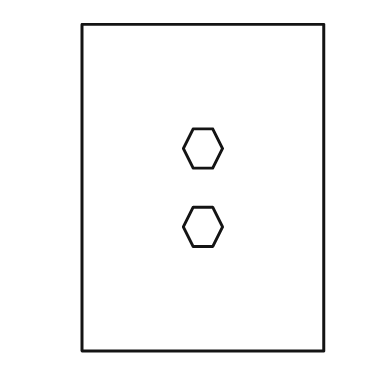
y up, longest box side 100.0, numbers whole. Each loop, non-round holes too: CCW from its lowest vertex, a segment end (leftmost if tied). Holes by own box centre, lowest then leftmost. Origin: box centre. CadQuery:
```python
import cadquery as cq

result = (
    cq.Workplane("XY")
    .moveTo(-37.0, -50.0)
    .lineTo(37.0, -50.0)
    .lineTo(37.0, 50.0)
    .lineTo(-37.0, 50.0)
    .close()
    .moveTo(-3.0, -18.0)
    .lineTo(3.0, -18.0)
    .lineTo(6.0, -12.0)
    .lineTo(3.0, -6.0)
    .lineTo(-3.0, -6.0)
    .lineTo(-6.0, -12.0)
    .close()
    .moveTo(-3.0, 6.0)
    .lineTo(3.0, 6.0)
    .lineTo(6.0, 12.0)
    .lineTo(3.0, 18.0)
    .lineTo(-3.0, 18.0)
    .lineTo(-6.0, 12.0)
    .close()
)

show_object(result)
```